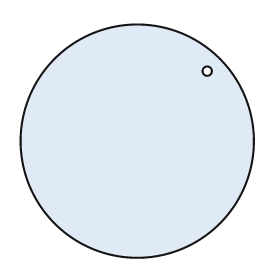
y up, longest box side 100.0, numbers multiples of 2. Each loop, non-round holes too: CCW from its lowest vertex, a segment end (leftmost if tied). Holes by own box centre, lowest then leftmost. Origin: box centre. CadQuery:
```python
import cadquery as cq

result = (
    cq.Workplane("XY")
    .moveTo(0.0, 0.0)
    .circle(50.0)
    .moveTo(30.0, 30.0)
    .circle(2.0)
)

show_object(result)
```